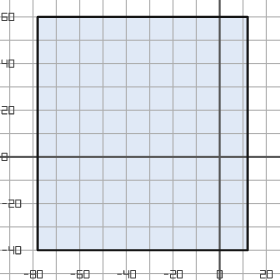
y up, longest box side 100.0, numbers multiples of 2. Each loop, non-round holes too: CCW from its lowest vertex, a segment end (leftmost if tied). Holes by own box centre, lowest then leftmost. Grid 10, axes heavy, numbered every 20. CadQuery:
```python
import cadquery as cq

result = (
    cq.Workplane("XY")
    .moveTo(-78.0, -40.0)
    .lineTo(12.0, -40.0)
    .lineTo(12.0, 60.0)
    .lineTo(-78.0, 60.0)
    .close()
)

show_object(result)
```